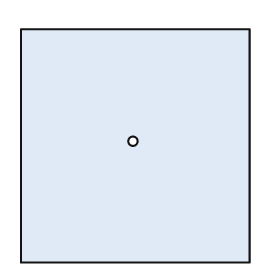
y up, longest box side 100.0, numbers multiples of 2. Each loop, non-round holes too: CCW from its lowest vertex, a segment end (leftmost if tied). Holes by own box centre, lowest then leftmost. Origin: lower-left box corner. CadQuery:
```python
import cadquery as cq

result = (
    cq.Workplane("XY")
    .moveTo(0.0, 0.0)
    .lineTo(98.0, 0.0)
    .lineTo(98.0, 100.0)
    .lineTo(0.0, 100.0)
    .close()
    .moveTo(48.0, 52.0)
    .circle(2.0)
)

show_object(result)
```